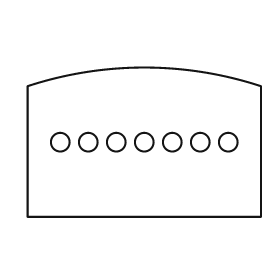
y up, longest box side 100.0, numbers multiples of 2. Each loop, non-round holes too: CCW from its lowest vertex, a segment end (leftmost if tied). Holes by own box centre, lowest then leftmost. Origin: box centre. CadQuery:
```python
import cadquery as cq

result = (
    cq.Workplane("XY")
    .moveTo(-50.0, -32.0)
    .lineTo(50.0, -32.0)
    .lineTo(50.0, 24.0)
    .threePointArc((0.0, 32.0), (-50.0, 24.0))
    .close()
    .moveTo(-36.0, 0.0)
    .circle(4.0)
    .moveTo(-24.0, 0.0)
    .circle(4.0)
    .moveTo(-12.0, 0.0)
    .circle(4.0)
    .moveTo(0.0, 0.0)
    .circle(4.0)
    .moveTo(12.0, 0.0)
    .circle(4.0)
    .moveTo(24.0, 0.0)
    .circle(4.0)
    .moveTo(36.0, 0.0)
    .circle(4.0)
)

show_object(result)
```